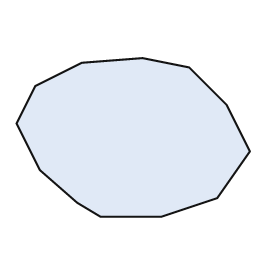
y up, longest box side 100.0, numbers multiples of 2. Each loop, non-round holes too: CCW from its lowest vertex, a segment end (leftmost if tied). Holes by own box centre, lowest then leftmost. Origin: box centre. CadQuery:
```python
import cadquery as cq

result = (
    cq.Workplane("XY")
    .moveTo(-14.0, -34.0)
    .lineTo(12.0, -34.0)
    .lineTo(36.0, -26.0)
    .lineTo(50.0, -6.0)
    .lineTo(40.0, 14.0)
    .lineTo(24.0, 30.0)
    .lineTo(4.0, 34.0)
    .lineTo(-22.0, 32.0)
    .lineTo(-42.0, 22.0)
    .lineTo(-50.0, 6.0)
    .lineTo(-40.0, -14.0)
    .lineTo(-24.0, -28.0)
    .close()
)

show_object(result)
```